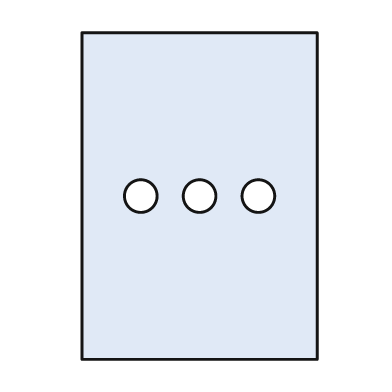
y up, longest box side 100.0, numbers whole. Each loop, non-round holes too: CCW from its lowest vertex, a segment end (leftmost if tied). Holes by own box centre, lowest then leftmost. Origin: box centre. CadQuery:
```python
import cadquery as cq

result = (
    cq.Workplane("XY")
    .moveTo(-36.0, -50.0)
    .lineTo(36.0, -50.0)
    .lineTo(36.0, 50.0)
    .lineTo(-36.0, 50.0)
    .close()
    .moveTo(-18.0, 0.0)
    .circle(5.0)
    .moveTo(0.0, 0.0)
    .circle(5.0)
    .moveTo(18.0, 0.0)
    .circle(5.0)
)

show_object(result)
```